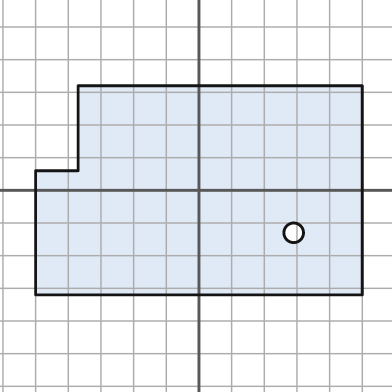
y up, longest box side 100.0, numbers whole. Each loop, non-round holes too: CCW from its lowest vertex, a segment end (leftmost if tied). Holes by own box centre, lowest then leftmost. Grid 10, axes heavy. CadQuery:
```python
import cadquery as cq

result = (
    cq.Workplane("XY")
    .moveTo(-50.0, -32.0)
    .lineTo(50.0, -32.0)
    .lineTo(50.0, 32.0)
    .lineTo(-37.0, 32.0)
    .lineTo(-37.0, 6.0)
    .lineTo(-50.0, 6.0)
    .close()
    .moveTo(29.0, -13.0)
    .circle(3.0)
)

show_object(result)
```